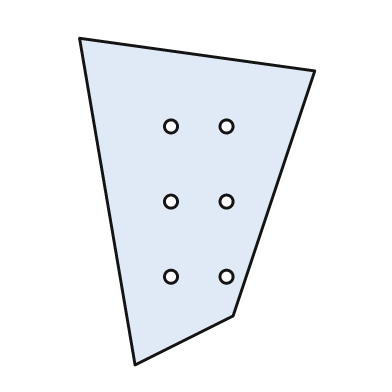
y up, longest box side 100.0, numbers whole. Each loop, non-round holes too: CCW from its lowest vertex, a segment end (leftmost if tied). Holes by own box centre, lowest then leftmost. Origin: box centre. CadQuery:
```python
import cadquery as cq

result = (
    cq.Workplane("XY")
    .moveTo(-19.0, -50.0)
    .lineTo(11.0, -35.0)
    .lineTo(36.0, 40.0)
    .lineTo(-36.0, 50.0)
    .close()
    .moveTo(-8.0, -23.0)
    .circle(2.0)
    .moveTo(9.0, -23.0)
    .circle(2.0)
    .moveTo(-8.0, 0.0)
    .circle(2.0)
    .moveTo(9.0, 0.0)
    .circle(2.0)
    .moveTo(-8.0, 23.0)
    .circle(2.0)
    .moveTo(9.0, 23.0)
    .circle(2.0)
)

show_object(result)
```